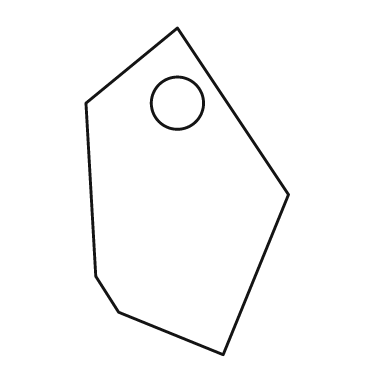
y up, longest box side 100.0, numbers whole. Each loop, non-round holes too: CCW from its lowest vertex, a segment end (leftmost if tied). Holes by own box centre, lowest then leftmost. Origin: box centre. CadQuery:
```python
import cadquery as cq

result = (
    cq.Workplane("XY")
    .moveTo(11.0, -50.0)
    .lineTo(31.0, -1.0)
    .lineTo(-3.0, 50.0)
    .lineTo(-31.0, 27.0)
    .lineTo(-28.0, -26.0)
    .lineTo(-21.0, -37.0)
    .close()
    .moveTo(-3.0, 27.0)
    .circle(8.0)
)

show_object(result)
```